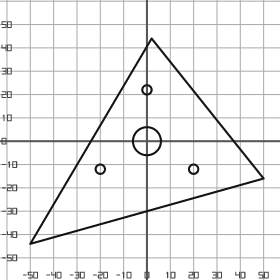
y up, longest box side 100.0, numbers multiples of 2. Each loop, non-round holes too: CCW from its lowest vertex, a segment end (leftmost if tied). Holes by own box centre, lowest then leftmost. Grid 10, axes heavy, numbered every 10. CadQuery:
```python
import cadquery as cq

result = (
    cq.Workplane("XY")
    .moveTo(-50.0, -44.0)
    .lineTo(50.0, -16.0)
    .lineTo(2.0, 44.0)
    .close()
    .moveTo(-20.0, -12.0)
    .circle(2.0)
    .moveTo(20.0, -12.0)
    .circle(2.0)
    .moveTo(0.0, 0.0)
    .circle(6.0)
    .moveTo(0.0, 22.0)
    .circle(2.0)
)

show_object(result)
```